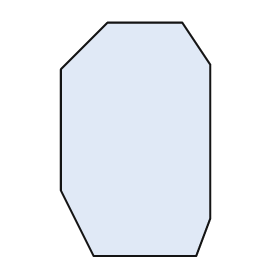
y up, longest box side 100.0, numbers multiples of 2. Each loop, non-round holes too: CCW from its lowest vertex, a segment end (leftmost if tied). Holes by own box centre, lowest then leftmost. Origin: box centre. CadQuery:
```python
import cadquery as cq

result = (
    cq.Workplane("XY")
    .moveTo(-18.0, -50.0)
    .lineTo(26.0, -50.0)
    .lineTo(32.0, -34.0)
    .lineTo(32.0, 32.0)
    .lineTo(20.0, 50.0)
    .lineTo(-12.0, 50.0)
    .lineTo(-32.0, 30.0)
    .lineTo(-32.0, -22.0)
    .close()
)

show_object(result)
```